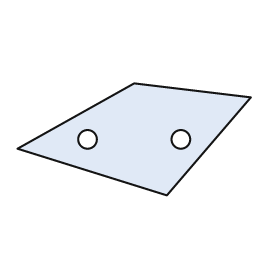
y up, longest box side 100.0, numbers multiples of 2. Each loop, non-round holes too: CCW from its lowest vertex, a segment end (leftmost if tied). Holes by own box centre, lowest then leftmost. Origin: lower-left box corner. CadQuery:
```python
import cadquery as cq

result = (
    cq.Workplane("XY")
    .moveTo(64.0, 0.0)
    .lineTo(100.0, 42.0)
    .lineTo(50.0, 48.0)
    .lineTo(0.0, 20.0)
    .close()
    .moveTo(30.0, 24.0)
    .circle(4.0)
    .moveTo(70.0, 24.0)
    .circle(4.0)
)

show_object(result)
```